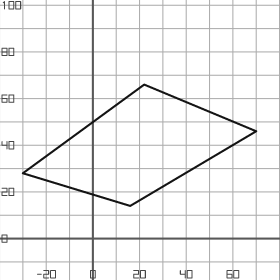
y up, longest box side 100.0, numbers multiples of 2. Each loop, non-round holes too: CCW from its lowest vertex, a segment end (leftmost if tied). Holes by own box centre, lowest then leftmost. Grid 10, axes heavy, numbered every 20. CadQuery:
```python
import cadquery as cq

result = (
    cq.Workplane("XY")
    .moveTo(16.0, 14.0)
    .lineTo(70.0, 46.0)
    .lineTo(22.0, 66.0)
    .lineTo(-30.0, 28.0)
    .close()
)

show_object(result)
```